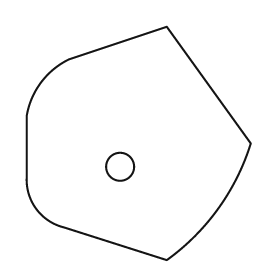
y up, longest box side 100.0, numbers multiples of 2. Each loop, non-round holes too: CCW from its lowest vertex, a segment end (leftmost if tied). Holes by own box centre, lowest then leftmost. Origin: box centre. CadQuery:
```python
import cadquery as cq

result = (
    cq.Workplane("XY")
    .moveTo(12.0, -50.0)
    .threePointArc((34.0, -28.0), (48.0, 0.0))
    .lineTo(12.0, 50.0)
    .lineTo(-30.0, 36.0)
    .threePointArc((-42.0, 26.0), (-48.0, 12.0))
    .lineTo(-48.0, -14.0)
    .threePointArc((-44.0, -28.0), (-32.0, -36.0))
    .close()
    .moveTo(-8.0, -10.0)
    .circle(6.0)
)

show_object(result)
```